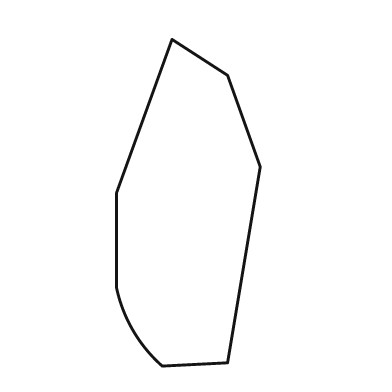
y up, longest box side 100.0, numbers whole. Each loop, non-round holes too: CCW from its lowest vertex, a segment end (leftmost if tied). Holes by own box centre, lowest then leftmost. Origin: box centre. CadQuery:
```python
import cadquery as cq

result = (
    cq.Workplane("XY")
    .moveTo(-8.0, -50.0)
    .lineTo(12.0, -49.0)
    .lineTo(22.0, 11.0)
    .lineTo(12.0, 39.0)
    .lineTo(-5.0, 50.0)
    .lineTo(-22.0, 3.0)
    .lineTo(-22.0, -26.0)
    .threePointArc((-17.0, -39.0), (-8.0, -50.0))
    .close()
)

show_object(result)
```